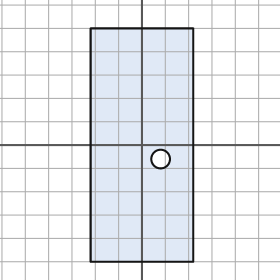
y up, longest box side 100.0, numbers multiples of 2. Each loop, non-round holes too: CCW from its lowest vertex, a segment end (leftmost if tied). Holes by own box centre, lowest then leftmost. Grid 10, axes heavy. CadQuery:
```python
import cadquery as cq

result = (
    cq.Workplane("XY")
    .moveTo(-22.0, -50.0)
    .lineTo(22.0, -50.0)
    .lineTo(22.0, 50.0)
    .lineTo(-22.0, 50.0)
    .close()
    .moveTo(8.0, -6.0)
    .circle(4.0)
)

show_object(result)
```